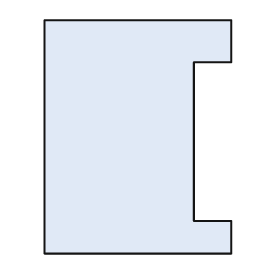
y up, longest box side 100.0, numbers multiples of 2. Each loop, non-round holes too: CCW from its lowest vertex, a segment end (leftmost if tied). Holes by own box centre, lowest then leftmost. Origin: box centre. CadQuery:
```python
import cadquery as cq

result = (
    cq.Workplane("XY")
    .moveTo(-40.0, -50.0)
    .lineTo(40.0, -50.0)
    .lineTo(40.0, -36.0)
    .lineTo(24.0, -36.0)
    .lineTo(24.0, 32.0)
    .lineTo(40.0, 32.0)
    .lineTo(40.0, 50.0)
    .lineTo(-40.0, 50.0)
    .close()
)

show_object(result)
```